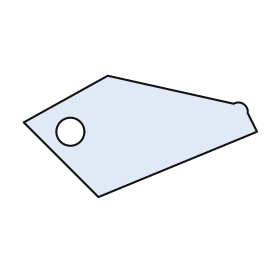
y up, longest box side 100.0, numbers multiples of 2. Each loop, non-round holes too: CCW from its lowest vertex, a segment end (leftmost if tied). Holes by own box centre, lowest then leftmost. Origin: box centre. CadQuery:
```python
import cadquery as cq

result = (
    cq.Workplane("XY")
    .moveTo(-18.0, -26.0)
    .lineTo(50.0, 2.0)
    .lineTo(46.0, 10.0)
    .threePointArc((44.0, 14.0), (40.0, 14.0))
    .lineTo(-14.0, 26.0)
    .lineTo(-50.0, 6.0)
    .close()
    .moveTo(-30.0, 2.0)
    .circle(6.0)
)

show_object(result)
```